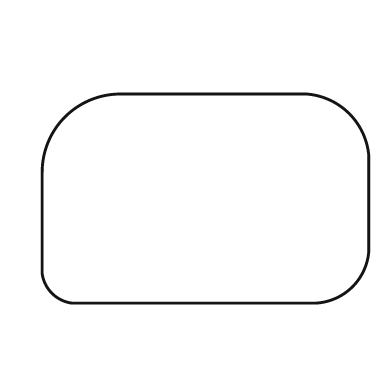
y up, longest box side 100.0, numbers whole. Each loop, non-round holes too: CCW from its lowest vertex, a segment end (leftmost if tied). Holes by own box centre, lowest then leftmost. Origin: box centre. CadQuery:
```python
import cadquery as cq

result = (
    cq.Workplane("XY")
    .moveTo(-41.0, -32.0)
    .lineTo(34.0, -32.0)
    .threePointArc((45.0, -27.0), (50.0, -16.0))
    .lineTo(50.0, 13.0)
    .threePointArc((44.0, 26.0), (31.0, 32.0))
    .lineTo(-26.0, 32.0)
    .threePointArc((-43.0, 25.0), (-50.0, 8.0))
    .lineTo(-50.0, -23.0)
    .threePointArc((-47.0, -29.0), (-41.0, -32.0))
    .close()
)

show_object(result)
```